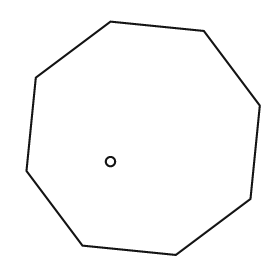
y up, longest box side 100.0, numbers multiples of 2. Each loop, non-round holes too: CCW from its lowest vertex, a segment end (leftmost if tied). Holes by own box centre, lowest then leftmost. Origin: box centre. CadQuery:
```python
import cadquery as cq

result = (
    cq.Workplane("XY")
    .moveTo(14.0, -50.0)
    .lineTo(46.0, -26.0)
    .lineTo(50.0, 14.0)
    .lineTo(26.0, 46.0)
    .lineTo(-14.0, 50.0)
    .lineTo(-46.0, 26.0)
    .lineTo(-50.0, -14.0)
    .lineTo(-26.0, -46.0)
    .close()
    .moveTo(-14.0, -10.0)
    .circle(2.0)
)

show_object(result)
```